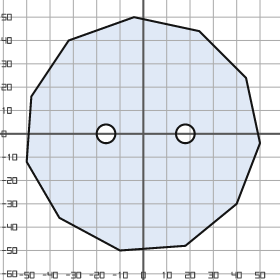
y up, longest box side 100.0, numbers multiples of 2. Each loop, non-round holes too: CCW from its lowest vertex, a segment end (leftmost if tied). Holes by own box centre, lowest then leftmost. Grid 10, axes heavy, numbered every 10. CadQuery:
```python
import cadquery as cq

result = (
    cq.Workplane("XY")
    .moveTo(-10.0, -50.0)
    .lineTo(18.0, -48.0)
    .lineTo(40.0, -30.0)
    .lineTo(50.0, -4.0)
    .lineTo(44.0, 24.0)
    .lineTo(24.0, 44.0)
    .lineTo(-4.0, 50.0)
    .lineTo(-32.0, 40.0)
    .lineTo(-48.0, 16.0)
    .lineTo(-50.0, -12.0)
    .lineTo(-36.0, -36.0)
    .close()
    .moveTo(-16.0, 0.0)
    .circle(4.0)
    .moveTo(18.0, 0.0)
    .circle(4.0)
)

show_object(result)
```